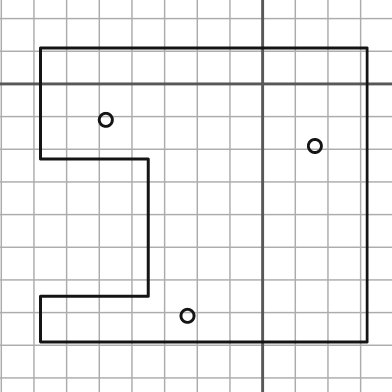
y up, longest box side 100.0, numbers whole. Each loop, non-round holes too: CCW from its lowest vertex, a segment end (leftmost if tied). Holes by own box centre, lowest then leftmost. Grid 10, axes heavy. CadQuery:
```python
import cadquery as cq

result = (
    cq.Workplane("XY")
    .moveTo(-68.0, -79.0)
    .lineTo(32.0, -79.0)
    .lineTo(32.0, 11.0)
    .lineTo(-68.0, 11.0)
    .lineTo(-68.0, -23.0)
    .lineTo(-35.0, -23.0)
    .lineTo(-35.0, -65.0)
    .lineTo(-68.0, -65.0)
    .close()
    .moveTo(-23.0, -71.0)
    .circle(2.0)
    .moveTo(16.0, -19.0)
    .circle(2.0)
    .moveTo(-48.0, -11.0)
    .circle(2.0)
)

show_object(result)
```